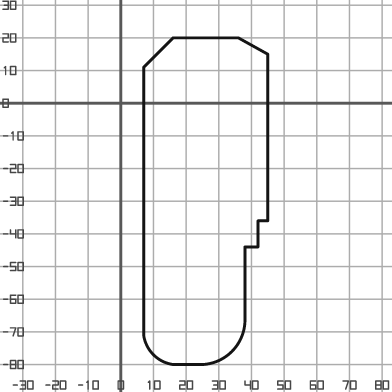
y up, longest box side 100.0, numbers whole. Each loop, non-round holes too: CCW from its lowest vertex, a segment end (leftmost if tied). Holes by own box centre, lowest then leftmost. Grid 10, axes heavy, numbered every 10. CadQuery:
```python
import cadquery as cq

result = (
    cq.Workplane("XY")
    .moveTo(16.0, -80.0)
    .lineTo(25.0, -80.0)
    .threePointArc((34.0, -76.0), (38.0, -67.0))
    .lineTo(38.0, -44.0)
    .lineTo(42.0, -44.0)
    .lineTo(42.0, -36.0)
    .lineTo(45.0, -36.0)
    .lineTo(45.0, 15.0)
    .lineTo(36.0, 20.0)
    .lineTo(16.0, 20.0)
    .lineTo(7.0, 11.0)
    .lineTo(7.0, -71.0)
    .threePointArc((10.0, -77.0), (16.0, -80.0))
    .close()
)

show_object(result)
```